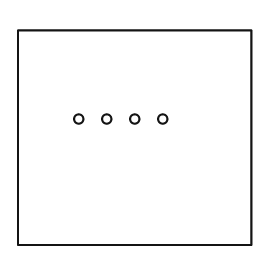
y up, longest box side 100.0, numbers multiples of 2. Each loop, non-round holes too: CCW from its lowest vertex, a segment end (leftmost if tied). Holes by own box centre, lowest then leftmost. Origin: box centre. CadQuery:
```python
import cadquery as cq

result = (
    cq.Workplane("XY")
    .moveTo(-50.0, -46.0)
    .lineTo(50.0, -46.0)
    .lineTo(50.0, 46.0)
    .lineTo(-50.0, 46.0)
    .close()
    .moveTo(-24.0, 8.0)
    .circle(2.0)
    .moveTo(-12.0, 8.0)
    .circle(2.0)
    .moveTo(0.0, 8.0)
    .circle(2.0)
    .moveTo(12.0, 8.0)
    .circle(2.0)
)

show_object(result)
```